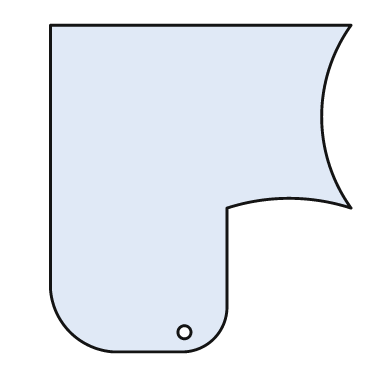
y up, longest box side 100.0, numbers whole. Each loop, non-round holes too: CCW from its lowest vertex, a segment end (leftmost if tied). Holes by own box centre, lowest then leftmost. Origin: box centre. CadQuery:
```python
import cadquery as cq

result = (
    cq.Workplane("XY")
    .moveTo(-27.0, -50.0)
    .lineTo(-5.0, -50.0)
    .threePointArc((4.0, -46.0), (8.0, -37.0))
    .lineTo(8.0, -6.0)
    .threePointArc((27.0, -3.0), (46.0, -6.0))
    .threePointArc((37.0, 22.0), (46.0, 50.0))
    .lineTo(-46.0, 50.0)
    .lineTo(-46.0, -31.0)
    .threePointArc((-40.0, -44.0), (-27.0, -50.0))
    .close()
    .moveTo(-5.0, -44.0)
    .circle(2.0)
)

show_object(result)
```